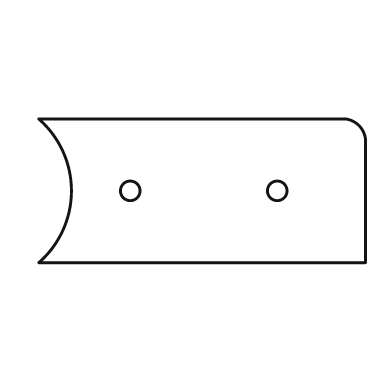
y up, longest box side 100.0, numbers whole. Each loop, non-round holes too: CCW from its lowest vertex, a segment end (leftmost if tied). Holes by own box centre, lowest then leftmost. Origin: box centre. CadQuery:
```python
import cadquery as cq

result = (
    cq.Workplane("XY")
    .moveTo(-50.0, -22.0)
    .lineTo(50.0, -22.0)
    .lineTo(50.0, 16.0)
    .threePointArc((48.0, 20.0), (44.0, 22.0))
    .lineTo(-50.0, 22.0)
    .threePointArc((-40.0, 0.0), (-50.0, -22.0))
    .close()
    .moveTo(-22.0, 0.0)
    .circle(3.0)
    .moveTo(23.0, 0.0)
    .circle(3.0)
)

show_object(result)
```